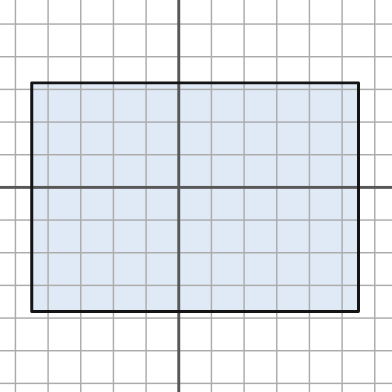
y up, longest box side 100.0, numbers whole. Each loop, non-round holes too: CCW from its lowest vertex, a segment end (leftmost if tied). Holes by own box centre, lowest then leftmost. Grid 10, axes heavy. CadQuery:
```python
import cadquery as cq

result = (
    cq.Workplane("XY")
    .moveTo(-45.0, -38.0)
    .lineTo(55.0, -38.0)
    .lineTo(55.0, 32.0)
    .lineTo(-45.0, 32.0)
    .close()
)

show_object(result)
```